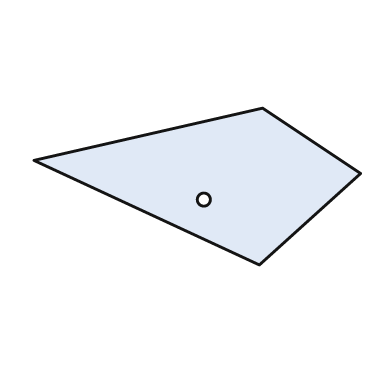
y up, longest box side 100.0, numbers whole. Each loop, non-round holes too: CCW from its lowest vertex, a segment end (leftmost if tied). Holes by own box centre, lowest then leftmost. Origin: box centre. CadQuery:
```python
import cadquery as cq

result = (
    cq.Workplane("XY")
    .moveTo(19.0, -24.0)
    .lineTo(50.0, 4.0)
    .lineTo(20.0, 24.0)
    .lineTo(-50.0, 8.0)
    .close()
    .moveTo(2.0, -4.0)
    .circle(2.0)
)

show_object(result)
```